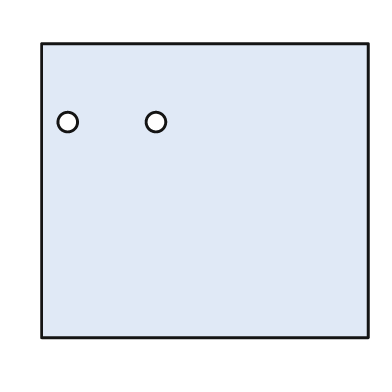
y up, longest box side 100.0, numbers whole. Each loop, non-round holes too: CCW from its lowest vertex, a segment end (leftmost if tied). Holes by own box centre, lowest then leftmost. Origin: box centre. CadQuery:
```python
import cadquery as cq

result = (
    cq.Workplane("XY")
    .moveTo(-50.0, -45.0)
    .lineTo(50.0, -45.0)
    .lineTo(50.0, 45.0)
    .lineTo(-50.0, 45.0)
    .close()
    .moveTo(-42.0, 21.0)
    .circle(3.0)
    .moveTo(-15.0, 21.0)
    .circle(3.0)
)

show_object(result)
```